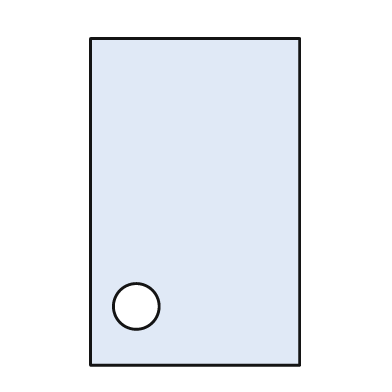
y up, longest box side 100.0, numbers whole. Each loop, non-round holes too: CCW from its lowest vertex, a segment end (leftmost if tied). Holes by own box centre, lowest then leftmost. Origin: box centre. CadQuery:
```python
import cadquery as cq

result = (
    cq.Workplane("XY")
    .moveTo(-32.0, -50.0)
    .lineTo(32.0, -50.0)
    .lineTo(32.0, 50.0)
    .lineTo(-32.0, 50.0)
    .close()
    .moveTo(-18.0, -32.0)
    .circle(7.0)
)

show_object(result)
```